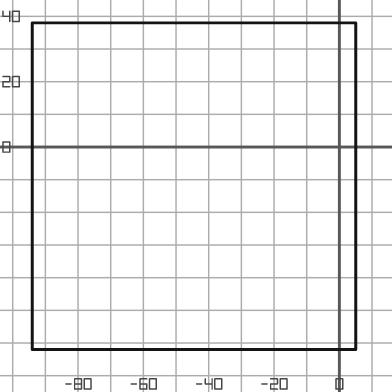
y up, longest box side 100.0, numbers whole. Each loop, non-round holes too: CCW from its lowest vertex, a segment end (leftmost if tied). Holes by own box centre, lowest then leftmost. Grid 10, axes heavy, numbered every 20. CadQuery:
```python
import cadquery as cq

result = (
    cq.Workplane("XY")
    .moveTo(-94.0, -62.0)
    .lineTo(5.0, -62.0)
    .lineTo(5.0, 38.0)
    .lineTo(-94.0, 38.0)
    .close()
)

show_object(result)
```